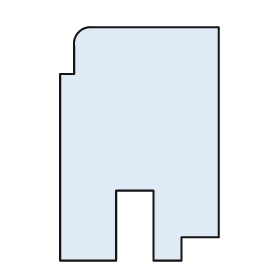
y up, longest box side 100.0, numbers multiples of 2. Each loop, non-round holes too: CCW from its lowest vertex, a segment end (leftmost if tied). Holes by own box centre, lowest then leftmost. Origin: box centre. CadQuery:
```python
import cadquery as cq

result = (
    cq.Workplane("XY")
    .moveTo(-34.0, -50.0)
    .lineTo(-10.0, -50.0)
    .lineTo(-10.0, -20.0)
    .lineTo(6.0, -20.0)
    .lineTo(6.0, -50.0)
    .lineTo(18.0, -50.0)
    .lineTo(18.0, -40.0)
    .lineTo(34.0, -40.0)
    .lineTo(34.0, 50.0)
    .lineTo(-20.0, 50.0)
    .threePointArc((-26.0, 48.0), (-28.0, 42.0))
    .lineTo(-28.0, 30.0)
    .lineTo(-34.0, 30.0)
    .close()
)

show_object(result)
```